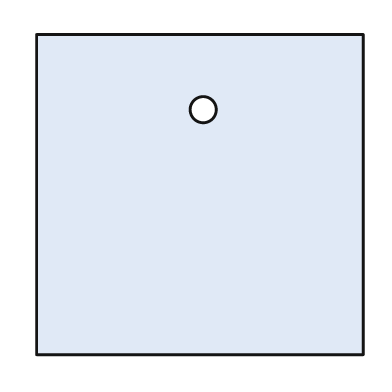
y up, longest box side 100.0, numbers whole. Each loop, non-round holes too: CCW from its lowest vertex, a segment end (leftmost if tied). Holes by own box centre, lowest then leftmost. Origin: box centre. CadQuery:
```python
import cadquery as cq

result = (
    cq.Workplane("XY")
    .moveTo(-50.0, -49.0)
    .lineTo(50.0, -49.0)
    .lineTo(50.0, 49.0)
    .lineTo(-50.0, 49.0)
    .close()
    .moveTo(1.0, 26.0)
    .circle(4.0)
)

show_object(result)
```